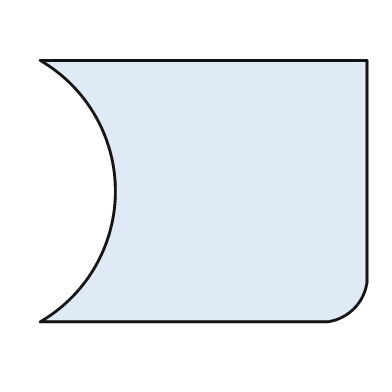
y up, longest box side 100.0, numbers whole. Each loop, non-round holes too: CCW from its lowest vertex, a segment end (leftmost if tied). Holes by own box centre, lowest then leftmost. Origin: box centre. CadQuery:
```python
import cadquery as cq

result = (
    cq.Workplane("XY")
    .moveTo(-50.0, -40.0)
    .lineTo(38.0, -40.0)
    .threePointArc((46.0, -36.0), (50.0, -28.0))
    .lineTo(50.0, 40.0)
    .lineTo(-50.0, 40.0)
    .threePointArc((-27.0, 0.0), (-50.0, -40.0))
    .close()
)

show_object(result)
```